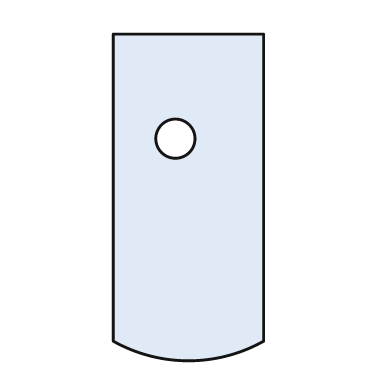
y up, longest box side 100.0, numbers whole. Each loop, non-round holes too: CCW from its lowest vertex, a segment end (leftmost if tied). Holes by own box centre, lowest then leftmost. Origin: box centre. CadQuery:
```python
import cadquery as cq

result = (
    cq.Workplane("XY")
    .moveTo(-23.0, -44.0)
    .threePointArc((0.0, -50.0), (23.0, -44.0))
    .lineTo(23.0, 50.0)
    .lineTo(-23.0, 50.0)
    .close()
    .moveTo(-4.0, 18.0)
    .circle(6.0)
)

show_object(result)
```